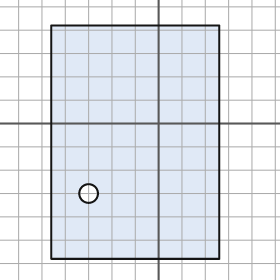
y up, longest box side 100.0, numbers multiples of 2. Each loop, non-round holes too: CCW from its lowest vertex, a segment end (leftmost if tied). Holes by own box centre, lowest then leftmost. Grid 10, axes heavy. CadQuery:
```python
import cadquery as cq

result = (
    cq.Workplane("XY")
    .moveTo(-46.0, -58.0)
    .lineTo(26.0, -58.0)
    .lineTo(26.0, 42.0)
    .lineTo(-46.0, 42.0)
    .close()
    .moveTo(-30.0, -30.0)
    .circle(4.0)
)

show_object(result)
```